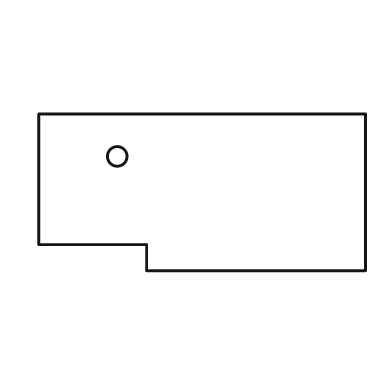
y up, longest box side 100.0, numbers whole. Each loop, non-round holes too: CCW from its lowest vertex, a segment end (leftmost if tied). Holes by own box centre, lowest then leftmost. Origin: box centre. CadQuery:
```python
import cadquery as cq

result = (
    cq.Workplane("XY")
    .moveTo(-17.0, -24.0)
    .lineTo(50.0, -24.0)
    .lineTo(50.0, 24.0)
    .lineTo(-50.0, 24.0)
    .lineTo(-50.0, -16.0)
    .lineTo(-17.0, -16.0)
    .close()
    .moveTo(-26.0, 11.0)
    .circle(3.0)
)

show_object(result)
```